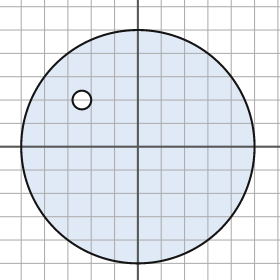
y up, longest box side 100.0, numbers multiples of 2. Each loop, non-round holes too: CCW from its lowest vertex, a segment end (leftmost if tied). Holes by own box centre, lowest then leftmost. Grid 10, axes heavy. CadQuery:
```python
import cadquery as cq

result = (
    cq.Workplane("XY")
    .moveTo(0.0, 0.0)
    .circle(50.0)
    .moveTo(-24.0, 20.0)
    .circle(4.0)
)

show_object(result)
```